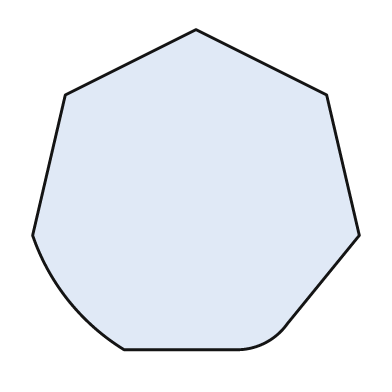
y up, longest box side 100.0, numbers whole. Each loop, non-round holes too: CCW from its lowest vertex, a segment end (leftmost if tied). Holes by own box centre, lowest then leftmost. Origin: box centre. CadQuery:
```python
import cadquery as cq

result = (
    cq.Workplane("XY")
    .moveTo(-22.0, -49.0)
    .lineTo(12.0, -49.0)
    .threePointArc((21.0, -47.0), (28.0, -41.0))
    .lineTo(50.0, -14.0)
    .lineTo(40.0, 29.0)
    .lineTo(0.0, 49.0)
    .lineTo(-40.0, 29.0)
    .lineTo(-50.0, -14.0)
    .threePointArc((-39.0, -34.0), (-22.0, -49.0))
    .close()
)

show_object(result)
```